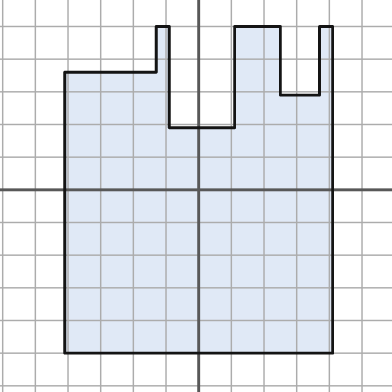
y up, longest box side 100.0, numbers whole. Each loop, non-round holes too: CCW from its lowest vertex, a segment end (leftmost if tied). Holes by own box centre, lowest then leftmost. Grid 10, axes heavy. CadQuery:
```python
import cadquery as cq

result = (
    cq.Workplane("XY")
    .moveTo(-41.0, -50.0)
    .lineTo(41.0, -50.0)
    .lineTo(41.0, 50.0)
    .lineTo(37.0, 50.0)
    .lineTo(37.0, 29.0)
    .lineTo(25.0, 29.0)
    .lineTo(25.0, 50.0)
    .lineTo(11.0, 50.0)
    .lineTo(11.0, 19.0)
    .lineTo(-9.0, 19.0)
    .lineTo(-9.0, 50.0)
    .lineTo(-13.0, 50.0)
    .lineTo(-13.0, 36.0)
    .lineTo(-41.0, 36.0)
    .close()
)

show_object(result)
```